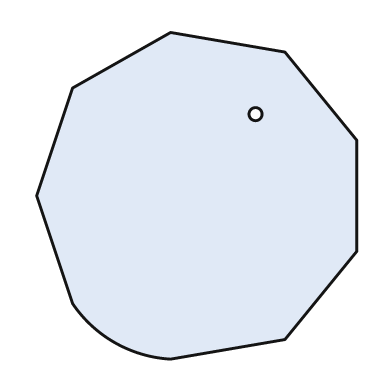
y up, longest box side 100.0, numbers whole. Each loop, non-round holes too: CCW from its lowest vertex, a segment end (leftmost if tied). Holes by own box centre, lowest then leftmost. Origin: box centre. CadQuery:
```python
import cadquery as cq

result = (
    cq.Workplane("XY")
    .moveTo(-8.0, -50.0)
    .lineTo(27.0, -44.0)
    .lineTo(49.0, -17.0)
    .lineTo(49.0, 17.0)
    .lineTo(27.0, 44.0)
    .lineTo(-8.0, 50.0)
    .lineTo(-38.0, 33.0)
    .lineTo(-49.0, 0.0)
    .lineTo(-38.0, -33.0)
    .threePointArc((-25.0, -45.0), (-8.0, -50.0))
    .close()
    .moveTo(18.0, 25.0)
    .circle(2.0)
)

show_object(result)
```